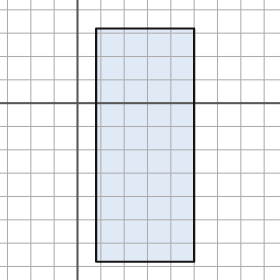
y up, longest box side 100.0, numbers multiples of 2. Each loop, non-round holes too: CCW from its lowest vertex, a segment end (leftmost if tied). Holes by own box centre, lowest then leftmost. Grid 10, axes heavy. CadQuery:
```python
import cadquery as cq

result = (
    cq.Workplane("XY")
    .moveTo(8.0, -68.0)
    .lineTo(50.0, -68.0)
    .lineTo(50.0, 32.0)
    .lineTo(8.0, 32.0)
    .close()
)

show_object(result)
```